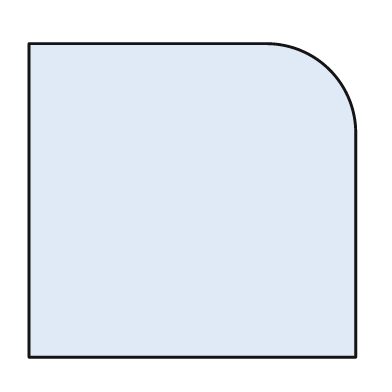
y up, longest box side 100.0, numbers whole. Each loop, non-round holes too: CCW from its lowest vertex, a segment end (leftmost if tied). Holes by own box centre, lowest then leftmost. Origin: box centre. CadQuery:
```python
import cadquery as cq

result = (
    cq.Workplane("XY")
    .moveTo(-50.0, -48.0)
    .lineTo(50.0, -48.0)
    .lineTo(50.0, 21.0)
    .threePointArc((42.0, 40.0), (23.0, 48.0))
    .lineTo(-50.0, 48.0)
    .close()
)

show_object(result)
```